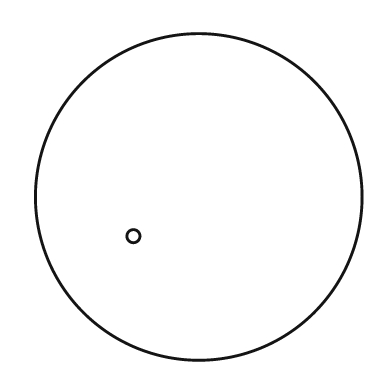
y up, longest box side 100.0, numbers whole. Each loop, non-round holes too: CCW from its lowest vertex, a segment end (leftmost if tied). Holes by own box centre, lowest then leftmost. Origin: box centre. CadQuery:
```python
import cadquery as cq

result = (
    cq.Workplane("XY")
    .moveTo(0.0, 0.0)
    .circle(50.0)
    .moveTo(-20.0, -12.0)
    .circle(2.0)
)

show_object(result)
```